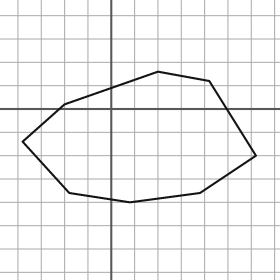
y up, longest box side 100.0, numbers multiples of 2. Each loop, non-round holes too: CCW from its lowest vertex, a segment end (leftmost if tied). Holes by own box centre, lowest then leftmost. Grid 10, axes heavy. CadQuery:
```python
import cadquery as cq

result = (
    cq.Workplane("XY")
    .moveTo(8.0, -40.0)
    .lineTo(38.0, -36.0)
    .lineTo(62.0, -20.0)
    .lineTo(42.0, 12.0)
    .lineTo(20.0, 16.0)
    .lineTo(-20.0, 2.0)
    .lineTo(-38.0, -14.0)
    .lineTo(-18.0, -36.0)
    .close()
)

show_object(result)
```